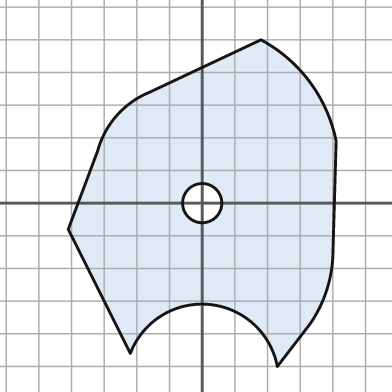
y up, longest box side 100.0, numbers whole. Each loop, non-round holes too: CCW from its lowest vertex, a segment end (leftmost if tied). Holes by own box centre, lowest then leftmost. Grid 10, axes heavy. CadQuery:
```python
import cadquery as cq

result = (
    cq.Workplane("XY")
    .moveTo(23.0, -50.0)
    .lineTo(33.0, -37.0)
    .threePointArc((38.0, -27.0), (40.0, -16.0))
    .lineTo(41.0, 19.0)
    .threePointArc((33.0, 37.0), (18.0, 50.0))
    .lineTo(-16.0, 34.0)
    .threePointArc((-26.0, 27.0), (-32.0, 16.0))
    .lineTo(-41.0, -8.0)
    .lineTo(-22.0, -46.0)
    .threePointArc((2.0, -31.0), (23.0, -50.0))
    .close()
    .moveTo(0.0, 0.0)
    .circle(6.0)
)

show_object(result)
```